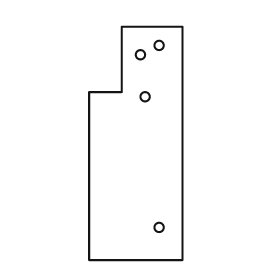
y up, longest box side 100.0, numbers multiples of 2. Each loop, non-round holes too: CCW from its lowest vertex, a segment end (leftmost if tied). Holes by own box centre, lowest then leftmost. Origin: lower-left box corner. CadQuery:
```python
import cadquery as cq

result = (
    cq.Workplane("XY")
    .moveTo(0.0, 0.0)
    .lineTo(40.0, 0.0)
    .lineTo(40.0, 100.0)
    .lineTo(14.0, 100.0)
    .lineTo(14.0, 72.0)
    .lineTo(0.0, 72.0)
    .close()
    .moveTo(30.0, 14.0)
    .circle(2.0)
    .moveTo(24.0, 70.0)
    .circle(2.0)
    .moveTo(22.0, 88.0)
    .circle(2.0)
    .moveTo(30.0, 92.0)
    .circle(2.0)
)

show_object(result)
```